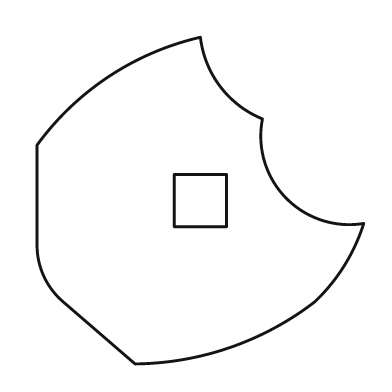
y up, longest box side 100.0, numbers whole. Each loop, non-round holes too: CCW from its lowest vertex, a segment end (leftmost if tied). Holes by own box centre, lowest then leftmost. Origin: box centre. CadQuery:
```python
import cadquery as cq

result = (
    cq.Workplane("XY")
    .moveTo(-20.0, -50.0)
    .threePointArc((9.0, -45.0), (35.0, -31.0))
    .threePointArc((44.0, -20.0), (50.0, -7.0))
    .threePointArc((26.0, 1.0), (19.0, 25.0))
    .threePointArc((6.0, 35.0), (0.0, 50.0))
    .threePointArc((-28.0, 38.0), (-50.0, 17.0))
    .lineTo(-50.0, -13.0)
    .threePointArc((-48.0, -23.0), (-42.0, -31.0))
    .close()
    .moveTo(-8.0, -8.0)
    .lineTo(8.0, -8.0)
    .lineTo(8.0, 8.0)
    .lineTo(-8.0, 8.0)
    .close()
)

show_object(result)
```